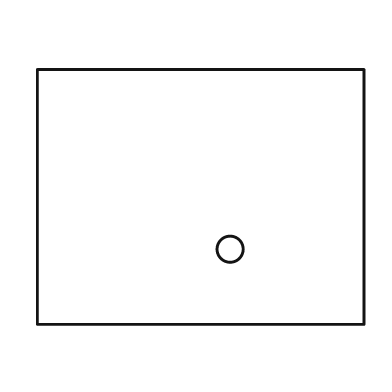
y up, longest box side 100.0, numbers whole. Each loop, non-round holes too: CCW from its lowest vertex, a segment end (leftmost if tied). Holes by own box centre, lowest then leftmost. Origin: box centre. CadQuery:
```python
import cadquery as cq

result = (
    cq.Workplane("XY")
    .moveTo(-50.0, -39.0)
    .lineTo(50.0, -39.0)
    .lineTo(50.0, 39.0)
    .lineTo(-50.0, 39.0)
    .close()
    .moveTo(9.0, -16.0)
    .circle(4.0)
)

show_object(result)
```